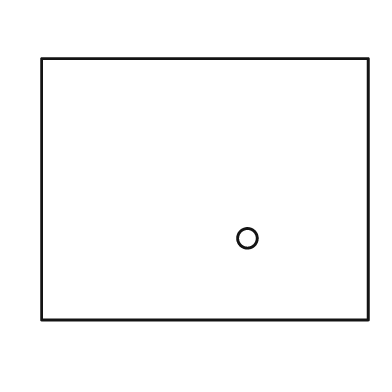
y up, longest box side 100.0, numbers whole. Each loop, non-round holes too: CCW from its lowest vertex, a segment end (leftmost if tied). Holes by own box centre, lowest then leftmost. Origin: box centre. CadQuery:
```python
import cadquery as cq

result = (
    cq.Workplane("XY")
    .moveTo(-50.0, -40.0)
    .lineTo(50.0, -40.0)
    .lineTo(50.0, 40.0)
    .lineTo(-50.0, 40.0)
    .close()
    .moveTo(13.0, -15.0)
    .circle(3.0)
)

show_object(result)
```